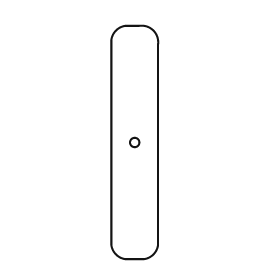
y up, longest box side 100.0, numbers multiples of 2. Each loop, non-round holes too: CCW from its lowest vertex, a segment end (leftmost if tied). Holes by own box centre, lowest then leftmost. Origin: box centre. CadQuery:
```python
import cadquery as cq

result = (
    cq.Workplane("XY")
    .moveTo(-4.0, -50.0)
    .lineTo(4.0, -50.0)
    .threePointArc((8.0, -48.0), (10.0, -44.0))
    .lineTo(10.0, 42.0)
    .threePointArc((8.0, 48.0), (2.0, 50.0))
    .lineTo(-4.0, 50.0)
    .threePointArc((-8.0, 48.0), (-10.0, 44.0))
    .lineTo(-10.0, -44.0)
    .threePointArc((-8.0, -48.0), (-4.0, -50.0))
    .close()
    .moveTo(0.0, 0.0)
    .circle(2.0)
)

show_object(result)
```